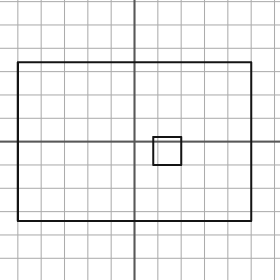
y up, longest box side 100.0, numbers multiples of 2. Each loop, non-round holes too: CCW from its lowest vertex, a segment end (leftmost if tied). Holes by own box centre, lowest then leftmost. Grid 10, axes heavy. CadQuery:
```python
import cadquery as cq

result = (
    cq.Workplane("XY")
    .moveTo(-50.0, -34.0)
    .lineTo(50.0, -34.0)
    .lineTo(50.0, 34.0)
    .lineTo(-50.0, 34.0)
    .close()
    .moveTo(8.0, -10.0)
    .lineTo(20.0, -10.0)
    .lineTo(20.0, 2.0)
    .lineTo(8.0, 2.0)
    .close()
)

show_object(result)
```